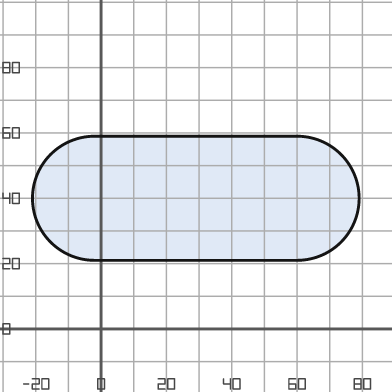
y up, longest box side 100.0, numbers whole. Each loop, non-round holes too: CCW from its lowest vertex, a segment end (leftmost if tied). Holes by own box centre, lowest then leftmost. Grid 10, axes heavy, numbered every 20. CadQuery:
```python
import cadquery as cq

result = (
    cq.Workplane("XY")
    .moveTo(-2.0, 21.0)
    .lineTo(60.0, 21.0)
    .threePointArc((79.0, 40.0), (60.0, 59.0))
    .lineTo(-2.0, 59.0)
    .threePointArc((-21.0, 40.0), (-2.0, 21.0))
    .close()
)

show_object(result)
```